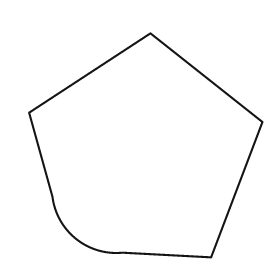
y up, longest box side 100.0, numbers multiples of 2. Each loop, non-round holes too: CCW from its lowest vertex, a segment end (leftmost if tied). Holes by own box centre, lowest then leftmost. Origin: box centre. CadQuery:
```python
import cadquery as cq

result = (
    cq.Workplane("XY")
    .moveTo(28.0, -48.0)
    .lineTo(50.0, 10.0)
    .lineTo(2.0, 48.0)
    .lineTo(-50.0, 14.0)
    .lineTo(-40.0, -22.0)
    .threePointArc((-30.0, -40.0), (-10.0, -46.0))
    .close()
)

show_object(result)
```